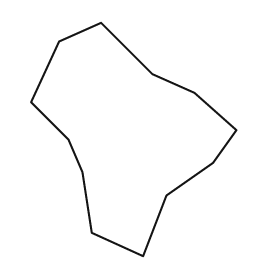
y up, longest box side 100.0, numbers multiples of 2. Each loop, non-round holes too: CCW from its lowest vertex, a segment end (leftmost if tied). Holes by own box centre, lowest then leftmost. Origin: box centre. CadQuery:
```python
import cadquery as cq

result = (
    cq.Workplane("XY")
    .moveTo(4.0, -50.0)
    .lineTo(14.0, -24.0)
    .lineTo(34.0, -10.0)
    .lineTo(44.0, 4.0)
    .lineTo(26.0, 20.0)
    .lineTo(8.0, 28.0)
    .lineTo(-14.0, 50.0)
    .lineTo(-32.0, 42.0)
    .lineTo(-44.0, 16.0)
    .lineTo(-28.0, 0.0)
    .lineTo(-22.0, -14.0)
    .lineTo(-18.0, -40.0)
    .close()
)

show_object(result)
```